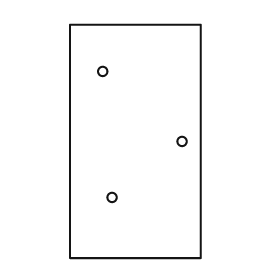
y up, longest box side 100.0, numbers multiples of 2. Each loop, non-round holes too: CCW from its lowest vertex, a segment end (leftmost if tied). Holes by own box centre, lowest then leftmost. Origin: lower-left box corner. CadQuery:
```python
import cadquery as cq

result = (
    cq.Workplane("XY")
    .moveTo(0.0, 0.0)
    .lineTo(56.0, 0.0)
    .lineTo(56.0, 100.0)
    .lineTo(0.0, 100.0)
    .close()
    .moveTo(18.0, 26.0)
    .circle(2.0)
    .moveTo(48.0, 50.0)
    .circle(2.0)
    .moveTo(14.0, 80.0)
    .circle(2.0)
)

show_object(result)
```